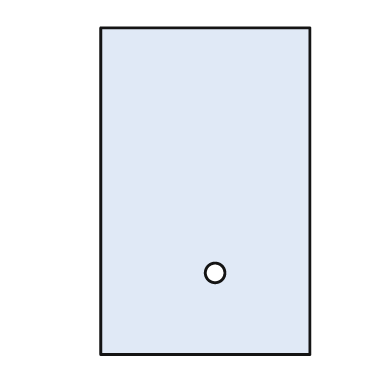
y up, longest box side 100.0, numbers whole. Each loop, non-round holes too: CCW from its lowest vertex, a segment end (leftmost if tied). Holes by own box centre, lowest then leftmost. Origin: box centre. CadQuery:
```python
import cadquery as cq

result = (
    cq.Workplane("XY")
    .moveTo(-32.0, -50.0)
    .lineTo(32.0, -50.0)
    .lineTo(32.0, 50.0)
    .lineTo(-32.0, 50.0)
    .close()
    .moveTo(3.0, -25.0)
    .circle(3.0)
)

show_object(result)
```